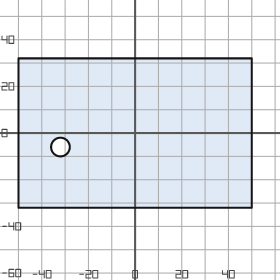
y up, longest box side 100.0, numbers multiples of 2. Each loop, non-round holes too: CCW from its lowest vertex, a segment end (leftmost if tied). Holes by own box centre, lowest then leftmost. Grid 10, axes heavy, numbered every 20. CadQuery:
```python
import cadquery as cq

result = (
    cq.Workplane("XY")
    .moveTo(-50.0, -32.0)
    .lineTo(50.0, -32.0)
    .lineTo(50.0, 32.0)
    .lineTo(-50.0, 32.0)
    .close()
    .moveTo(-32.0, -6.0)
    .circle(4.0)
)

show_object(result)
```